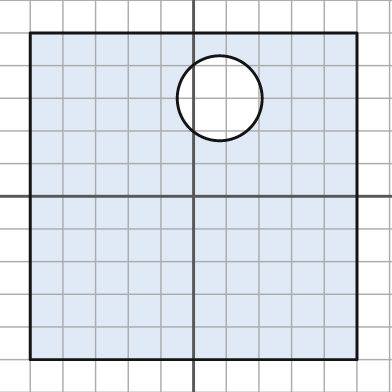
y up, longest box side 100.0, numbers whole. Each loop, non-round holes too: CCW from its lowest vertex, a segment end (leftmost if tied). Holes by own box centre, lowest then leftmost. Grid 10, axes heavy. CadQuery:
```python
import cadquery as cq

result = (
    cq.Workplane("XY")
    .moveTo(-50.0, -50.0)
    .lineTo(50.0, -50.0)
    .lineTo(50.0, 50.0)
    .lineTo(-50.0, 50.0)
    .close()
    .moveTo(8.0, 30.0)
    .circle(13.0)
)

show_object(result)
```